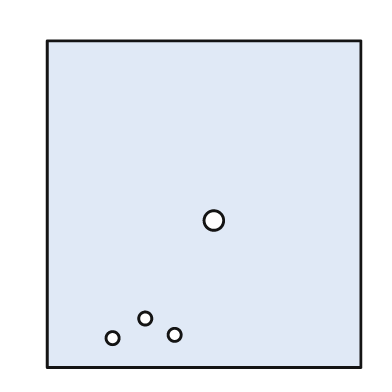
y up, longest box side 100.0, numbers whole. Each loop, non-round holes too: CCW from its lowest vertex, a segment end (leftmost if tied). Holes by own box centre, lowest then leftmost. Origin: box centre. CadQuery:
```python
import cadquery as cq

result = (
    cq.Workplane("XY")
    .moveTo(-48.0, -50.0)
    .lineTo(48.0, -50.0)
    .lineTo(48.0, 50.0)
    .lineTo(-48.0, 50.0)
    .close()
    .moveTo(-28.0, -41.0)
    .circle(2.0)
    .moveTo(-9.0, -40.0)
    .circle(2.0)
    .moveTo(-18.0, -35.0)
    .circle(2.0)
    .moveTo(3.0, -5.0)
    .circle(3.0)
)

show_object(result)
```